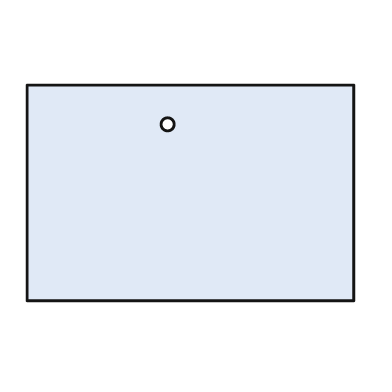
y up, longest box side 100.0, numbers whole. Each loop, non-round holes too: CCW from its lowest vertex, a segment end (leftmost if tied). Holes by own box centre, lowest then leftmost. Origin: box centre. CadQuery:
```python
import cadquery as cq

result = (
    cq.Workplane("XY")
    .moveTo(-50.0, -33.0)
    .lineTo(50.0, -33.0)
    .lineTo(50.0, 33.0)
    .lineTo(-50.0, 33.0)
    .close()
    .moveTo(-7.0, 21.0)
    .circle(2.0)
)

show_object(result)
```